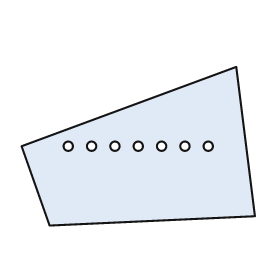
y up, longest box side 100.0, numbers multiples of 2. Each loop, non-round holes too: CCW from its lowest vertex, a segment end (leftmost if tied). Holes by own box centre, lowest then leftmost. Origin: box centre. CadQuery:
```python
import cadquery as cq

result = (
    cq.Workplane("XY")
    .moveTo(-38.0, -34.0)
    .lineTo(50.0, -30.0)
    .lineTo(42.0, 34.0)
    .lineTo(-50.0, 0.0)
    .close()
    .moveTo(-30.0, 0.0)
    .circle(2.0)
    .moveTo(-20.0, 0.0)
    .circle(2.0)
    .moveTo(-10.0, 0.0)
    .circle(2.0)
    .moveTo(0.0, 0.0)
    .circle(2.0)
    .moveTo(10.0, 0.0)
    .circle(2.0)
    .moveTo(20.0, 0.0)
    .circle(2.0)
    .moveTo(30.0, 0.0)
    .circle(2.0)
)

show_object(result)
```